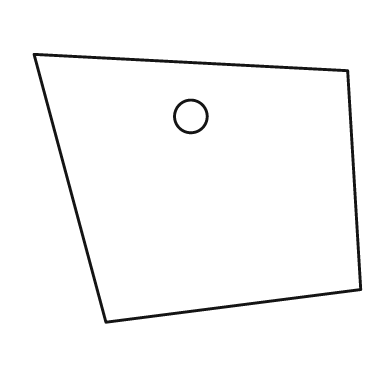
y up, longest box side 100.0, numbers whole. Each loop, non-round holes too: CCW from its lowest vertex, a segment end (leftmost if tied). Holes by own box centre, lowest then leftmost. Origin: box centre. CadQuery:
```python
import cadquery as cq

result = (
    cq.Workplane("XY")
    .moveTo(-28.0, -41.0)
    .lineTo(50.0, -31.0)
    .lineTo(46.0, 36.0)
    .lineTo(-50.0, 41.0)
    .close()
    .moveTo(-2.0, 22.0)
    .circle(5.0)
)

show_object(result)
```